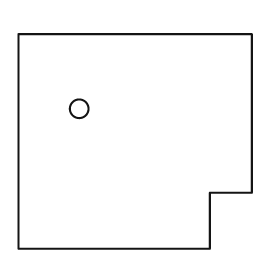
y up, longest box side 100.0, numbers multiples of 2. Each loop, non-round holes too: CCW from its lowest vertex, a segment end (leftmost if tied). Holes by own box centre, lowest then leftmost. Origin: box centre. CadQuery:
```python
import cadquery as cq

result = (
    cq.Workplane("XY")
    .moveTo(-50.0, -46.0)
    .lineTo(32.0, -46.0)
    .lineTo(32.0, -22.0)
    .lineTo(50.0, -22.0)
    .lineTo(50.0, 46.0)
    .lineTo(-50.0, 46.0)
    .close()
    .moveTo(-24.0, 14.0)
    .circle(4.0)
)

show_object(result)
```